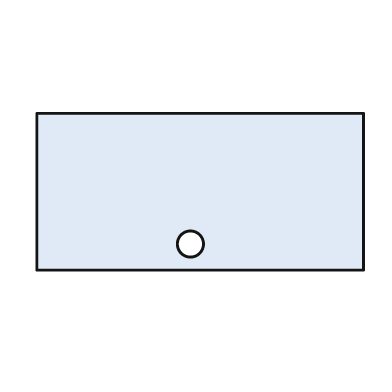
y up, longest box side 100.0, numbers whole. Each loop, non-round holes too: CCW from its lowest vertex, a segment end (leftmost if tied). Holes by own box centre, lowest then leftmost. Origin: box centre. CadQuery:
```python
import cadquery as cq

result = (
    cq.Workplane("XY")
    .moveTo(-50.0, -24.0)
    .lineTo(50.0, -24.0)
    .lineTo(50.0, 24.0)
    .lineTo(-50.0, 24.0)
    .close()
    .moveTo(-3.0, -16.0)
    .circle(4.0)
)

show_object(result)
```